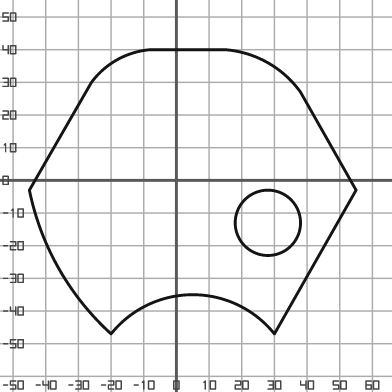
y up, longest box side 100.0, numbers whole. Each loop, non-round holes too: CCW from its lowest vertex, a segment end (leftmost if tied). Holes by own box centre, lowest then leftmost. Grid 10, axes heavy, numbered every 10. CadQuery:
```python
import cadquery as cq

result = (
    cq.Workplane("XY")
    .moveTo(-20.0, -47.0)
    .threePointArc((5.0, -35.0), (30.0, -47.0))
    .lineTo(55.0, -3.0)
    .lineTo(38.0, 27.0)
    .threePointArc((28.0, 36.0), (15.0, 40.0))
    .lineTo(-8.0, 40.0)
    .threePointArc((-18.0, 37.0), (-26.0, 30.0))
    .lineTo(-45.0, -3.0)
    .threePointArc((-36.0, -27.0), (-20.0, -47.0))
    .close()
    .moveTo(28.0, -13.0)
    .circle(10.0)
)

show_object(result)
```